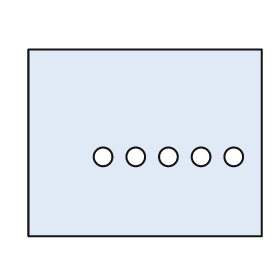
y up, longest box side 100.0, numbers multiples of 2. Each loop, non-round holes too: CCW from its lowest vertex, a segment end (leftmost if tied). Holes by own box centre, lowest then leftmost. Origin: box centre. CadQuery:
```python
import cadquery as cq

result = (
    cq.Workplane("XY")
    .moveTo(-50.0, -40.0)
    .lineTo(50.0, -40.0)
    .lineTo(50.0, 40.0)
    .lineTo(-50.0, 40.0)
    .close()
    .moveTo(-18.0, -6.0)
    .circle(4.0)
    .moveTo(-4.0, -6.0)
    .circle(4.0)
    .moveTo(10.0, -6.0)
    .circle(4.0)
    .moveTo(24.0, -6.0)
    .circle(4.0)
    .moveTo(38.0, -6.0)
    .circle(4.0)
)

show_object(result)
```